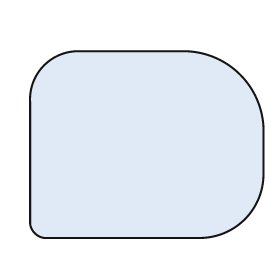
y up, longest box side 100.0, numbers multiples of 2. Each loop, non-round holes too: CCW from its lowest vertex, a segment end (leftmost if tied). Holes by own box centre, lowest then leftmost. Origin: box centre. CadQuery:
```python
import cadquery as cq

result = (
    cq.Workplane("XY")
    .moveTo(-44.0, -40.0)
    .lineTo(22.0, -40.0)
    .threePointArc((42.0, -32.0), (50.0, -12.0))
    .lineTo(50.0, 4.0)
    .threePointArc((40.0, 30.0), (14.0, 40.0))
    .lineTo(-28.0, 40.0)
    .threePointArc((-44.0, 34.0), (-50.0, 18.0))
    .lineTo(-50.0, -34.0)
    .threePointArc((-48.0, -38.0), (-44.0, -40.0))
    .close()
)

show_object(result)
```